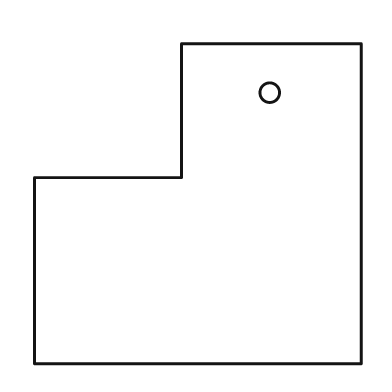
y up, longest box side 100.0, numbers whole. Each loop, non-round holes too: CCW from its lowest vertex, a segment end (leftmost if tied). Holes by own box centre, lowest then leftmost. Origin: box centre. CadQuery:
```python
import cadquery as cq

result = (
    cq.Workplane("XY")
    .moveTo(-50.0, -49.0)
    .lineTo(50.0, -49.0)
    .lineTo(50.0, 49.0)
    .lineTo(-5.0, 49.0)
    .lineTo(-5.0, 8.0)
    .lineTo(-50.0, 8.0)
    .close()
    .moveTo(22.0, 34.0)
    .circle(3.0)
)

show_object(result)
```